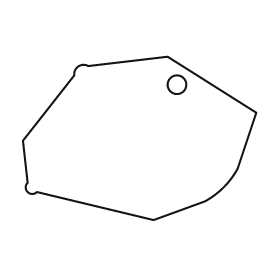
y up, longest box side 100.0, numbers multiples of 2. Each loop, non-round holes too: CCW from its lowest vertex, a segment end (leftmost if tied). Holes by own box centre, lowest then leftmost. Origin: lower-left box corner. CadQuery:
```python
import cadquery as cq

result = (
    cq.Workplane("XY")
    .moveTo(56.0, 0.0)
    .lineTo(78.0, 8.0)
    .threePointArc((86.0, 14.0), (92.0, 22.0))
    .lineTo(100.0, 46.0)
    .lineTo(62.0, 70.0)
    .lineTo(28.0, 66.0)
    .threePointArc((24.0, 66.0), (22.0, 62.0))
    .lineTo(0.0, 34.0)
    .lineTo(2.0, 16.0)
    .threePointArc((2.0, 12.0), (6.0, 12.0))
    .close()
    .moveTo(66.0, 58.0)
    .circle(4.0)
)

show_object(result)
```